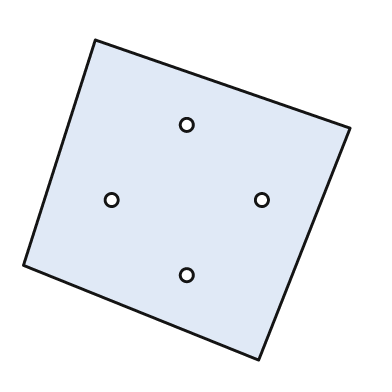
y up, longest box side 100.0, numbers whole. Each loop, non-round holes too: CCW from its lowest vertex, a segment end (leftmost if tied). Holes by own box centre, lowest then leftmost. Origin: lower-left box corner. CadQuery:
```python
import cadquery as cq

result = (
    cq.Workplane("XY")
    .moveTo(72.0, 0.0)
    .lineTo(100.0, 71.0)
    .lineTo(22.0, 98.0)
    .lineTo(0.0, 29.0)
    .close()
    .moveTo(50.0, 26.0)
    .circle(2.0)
    .moveTo(27.0, 49.0)
    .circle(2.0)
    .moveTo(73.0, 49.0)
    .circle(2.0)
    .moveTo(50.0, 72.0)
    .circle(2.0)
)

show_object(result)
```